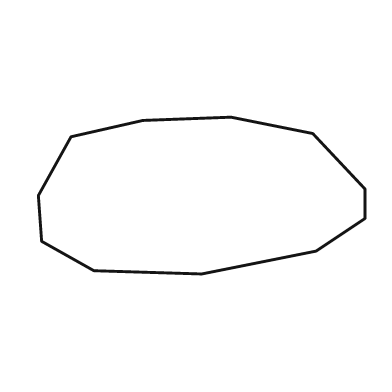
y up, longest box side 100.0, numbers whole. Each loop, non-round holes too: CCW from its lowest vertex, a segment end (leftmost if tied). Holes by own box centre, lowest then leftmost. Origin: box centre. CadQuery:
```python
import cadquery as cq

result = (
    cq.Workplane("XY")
    .moveTo(0.0, -24.0)
    .lineTo(35.0, -17.0)
    .lineTo(50.0, -7.0)
    .lineTo(50.0, 2.0)
    .lineTo(34.0, 19.0)
    .lineTo(9.0, 24.0)
    .lineTo(-18.0, 23.0)
    .lineTo(-40.0, 18.0)
    .lineTo(-50.0, 0.0)
    .lineTo(-49.0, -14.0)
    .lineTo(-33.0, -23.0)
    .close()
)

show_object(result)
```